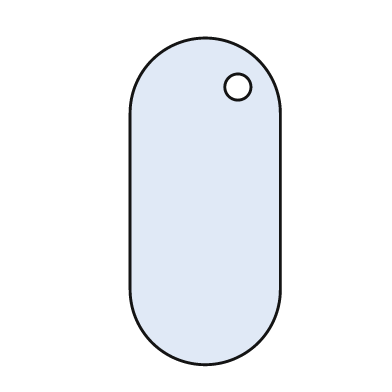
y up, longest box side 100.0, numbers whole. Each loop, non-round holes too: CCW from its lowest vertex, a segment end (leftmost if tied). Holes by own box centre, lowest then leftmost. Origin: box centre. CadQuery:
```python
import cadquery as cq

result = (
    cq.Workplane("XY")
    .moveTo(-23.0, -27.0)
    .threePointArc((0.0, -50.0), (23.0, -27.0))
    .lineTo(23.0, 27.0)
    .threePointArc((0.0, 50.0), (-23.0, 27.0))
    .close()
    .moveTo(10.0, 35.0)
    .circle(4.0)
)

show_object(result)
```